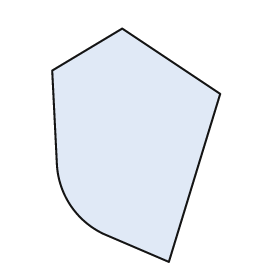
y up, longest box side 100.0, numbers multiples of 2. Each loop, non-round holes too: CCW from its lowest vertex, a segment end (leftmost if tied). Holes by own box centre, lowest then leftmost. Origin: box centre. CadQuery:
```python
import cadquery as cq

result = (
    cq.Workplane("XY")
    .moveTo(14.0, -50.0)
    .lineTo(36.0, 22.0)
    .lineTo(-6.0, 50.0)
    .lineTo(-36.0, 32.0)
    .lineTo(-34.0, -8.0)
    .threePointArc((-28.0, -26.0), (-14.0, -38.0))
    .close()
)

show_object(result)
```